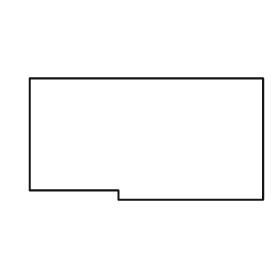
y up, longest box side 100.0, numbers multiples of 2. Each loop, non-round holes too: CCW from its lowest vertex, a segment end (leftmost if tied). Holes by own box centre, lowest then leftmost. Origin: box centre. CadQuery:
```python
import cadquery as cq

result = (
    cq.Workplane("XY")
    .moveTo(-12.0, -26.0)
    .lineTo(50.0, -26.0)
    .lineTo(50.0, 26.0)
    .lineTo(-50.0, 26.0)
    .lineTo(-50.0, -22.0)
    .lineTo(-12.0, -22.0)
    .close()
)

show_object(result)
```